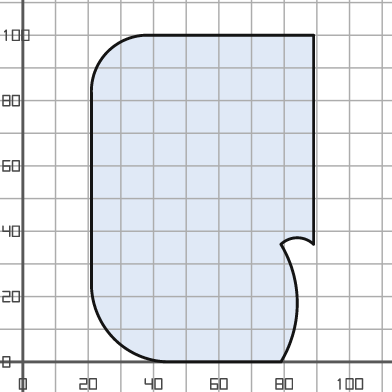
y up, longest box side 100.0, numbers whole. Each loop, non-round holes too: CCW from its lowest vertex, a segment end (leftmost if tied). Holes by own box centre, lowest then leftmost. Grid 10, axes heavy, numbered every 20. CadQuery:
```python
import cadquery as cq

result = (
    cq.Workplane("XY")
    .moveTo(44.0, 0.0)
    .lineTo(79.0, 0.0)
    .threePointArc((84.0, 18.0), (79.0, 36.0))
    .threePointArc((84.0, 38.0), (89.0, 36.0))
    .lineTo(89.0, 100.0)
    .lineTo(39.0, 100.0)
    .threePointArc((26.0, 95.0), (21.0, 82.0))
    .lineTo(21.0, 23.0)
    .threePointArc((28.0, 7.0), (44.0, 0.0))
    .close()
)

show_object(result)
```